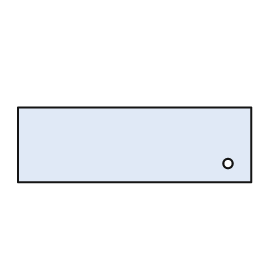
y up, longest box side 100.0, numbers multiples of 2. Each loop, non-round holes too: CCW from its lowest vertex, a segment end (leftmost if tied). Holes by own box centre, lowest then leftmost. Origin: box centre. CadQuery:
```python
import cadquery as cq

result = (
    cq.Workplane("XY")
    .moveTo(-50.0, -16.0)
    .lineTo(50.0, -16.0)
    .lineTo(50.0, 16.0)
    .lineTo(-50.0, 16.0)
    .close()
    .moveTo(40.0, -8.0)
    .circle(2.0)
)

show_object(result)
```